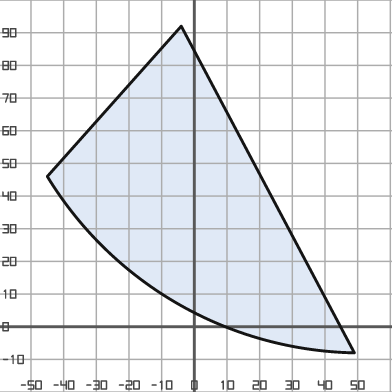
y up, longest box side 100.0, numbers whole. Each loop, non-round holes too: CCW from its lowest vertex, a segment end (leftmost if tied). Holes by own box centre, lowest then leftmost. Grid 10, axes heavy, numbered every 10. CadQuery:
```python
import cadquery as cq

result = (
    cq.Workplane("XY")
    .moveTo(49.0, -8.0)
    .lineTo(-4.0, 92.0)
    .lineTo(-45.0, 46.0)
    .threePointArc((-5.0, 7.0), (49.0, -8.0))
    .close()
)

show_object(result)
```